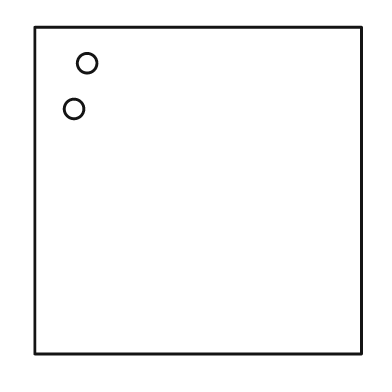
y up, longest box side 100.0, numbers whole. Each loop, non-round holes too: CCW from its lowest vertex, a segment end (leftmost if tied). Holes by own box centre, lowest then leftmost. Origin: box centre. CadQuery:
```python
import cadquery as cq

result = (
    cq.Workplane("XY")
    .moveTo(-50.0, -50.0)
    .lineTo(50.0, -50.0)
    .lineTo(50.0, 50.0)
    .lineTo(-50.0, 50.0)
    .close()
    .moveTo(-38.0, 25.0)
    .circle(3.0)
    .moveTo(-34.0, 39.0)
    .circle(3.0)
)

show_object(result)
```